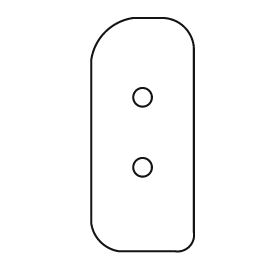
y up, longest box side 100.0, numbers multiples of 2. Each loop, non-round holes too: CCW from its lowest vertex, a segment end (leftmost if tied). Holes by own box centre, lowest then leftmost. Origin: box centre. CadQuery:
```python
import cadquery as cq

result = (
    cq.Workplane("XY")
    .moveTo(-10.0, -50.0)
    .lineTo(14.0, -50.0)
    .threePointArc((20.0, -48.0), (22.0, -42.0))
    .lineTo(22.0, 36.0)
    .threePointArc((18.0, 46.0), (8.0, 50.0))
    .lineTo(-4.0, 50.0)
    .threePointArc((-16.0, 44.0), (-22.0, 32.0))
    .lineTo(-22.0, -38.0)
    .threePointArc((-18.0, -46.0), (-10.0, -50.0))
    .close()
    .moveTo(0.0, -14.0)
    .circle(4.0)
    .moveTo(0.0, 16.0)
    .circle(4.0)
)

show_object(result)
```